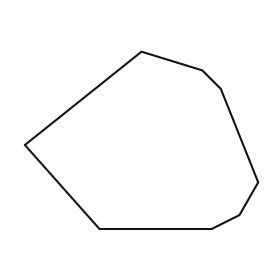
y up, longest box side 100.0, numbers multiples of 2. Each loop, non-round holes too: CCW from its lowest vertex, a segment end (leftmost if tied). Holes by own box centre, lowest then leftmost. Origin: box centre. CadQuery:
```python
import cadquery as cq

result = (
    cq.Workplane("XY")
    .moveTo(-18.0, -38.0)
    .lineTo(30.0, -38.0)
    .lineTo(42.0, -32.0)
    .lineTo(50.0, -18.0)
    .lineTo(34.0, 22.0)
    .lineTo(26.0, 30.0)
    .lineTo(0.0, 38.0)
    .lineTo(-50.0, -2.0)
    .close()
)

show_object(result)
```